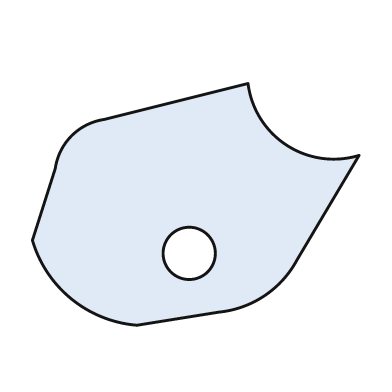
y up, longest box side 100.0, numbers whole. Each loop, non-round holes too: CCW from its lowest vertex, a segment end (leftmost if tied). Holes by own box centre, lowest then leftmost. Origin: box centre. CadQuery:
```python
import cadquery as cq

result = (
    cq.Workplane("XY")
    .moveTo(-18.0, -37.0)
    .lineTo(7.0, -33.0)
    .threePointArc((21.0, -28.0), (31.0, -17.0))
    .lineTo(50.0, 15.0)
    .threePointArc((28.0, 18.0), (16.0, 37.0))
    .lineTo(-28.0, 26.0)
    .threePointArc((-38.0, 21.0), (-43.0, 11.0))
    .lineTo(-50.0, -11.0)
    .threePointArc((-38.0, -29.0), (-18.0, -37.0))
    .close()
    .moveTo(-2.0, -15.0)
    .circle(8.0)
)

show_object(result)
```